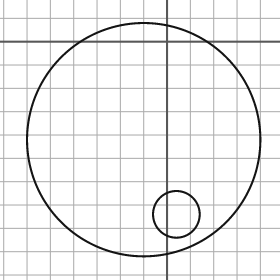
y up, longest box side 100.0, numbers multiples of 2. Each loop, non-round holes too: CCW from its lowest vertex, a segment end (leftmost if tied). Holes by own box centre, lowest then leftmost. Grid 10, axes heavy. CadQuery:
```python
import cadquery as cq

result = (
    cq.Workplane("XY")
    .moveTo(-10.0, -42.0)
    .circle(50.0)
    .moveTo(4.0, -74.0)
    .circle(10.0)
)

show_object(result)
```